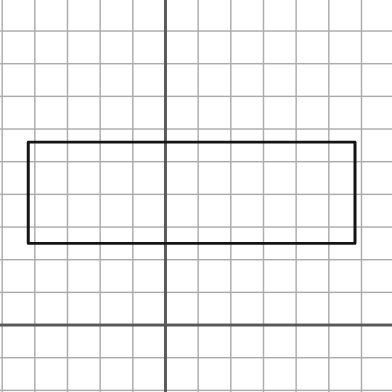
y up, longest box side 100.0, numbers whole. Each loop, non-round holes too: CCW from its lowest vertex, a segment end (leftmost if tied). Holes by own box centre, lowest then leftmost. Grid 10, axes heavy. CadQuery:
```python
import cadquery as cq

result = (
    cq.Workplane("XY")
    .moveTo(-42.0, 25.0)
    .lineTo(58.0, 25.0)
    .lineTo(58.0, 56.0)
    .lineTo(-42.0, 56.0)
    .close()
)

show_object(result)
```